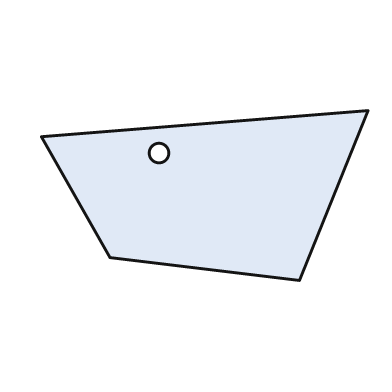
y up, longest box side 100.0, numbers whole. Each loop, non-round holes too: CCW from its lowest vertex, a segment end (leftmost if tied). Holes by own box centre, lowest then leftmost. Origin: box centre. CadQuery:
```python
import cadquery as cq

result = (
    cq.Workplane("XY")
    .moveTo(29.0, -26.0)
    .lineTo(50.0, 26.0)
    .lineTo(-50.0, 18.0)
    .lineTo(-29.0, -19.0)
    .close()
    .moveTo(-14.0, 13.0)
    .circle(3.0)
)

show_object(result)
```